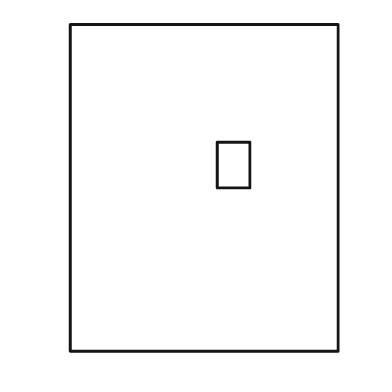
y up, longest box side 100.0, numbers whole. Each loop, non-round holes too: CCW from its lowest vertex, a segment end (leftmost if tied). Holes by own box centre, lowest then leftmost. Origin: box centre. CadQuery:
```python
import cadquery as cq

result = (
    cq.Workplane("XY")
    .moveTo(-41.0, -50.0)
    .lineTo(41.0, -50.0)
    .lineTo(41.0, 50.0)
    .lineTo(-41.0, 50.0)
    .close()
    .moveTo(4.0, 0.0)
    .lineTo(14.0, 0.0)
    .lineTo(14.0, 14.0)
    .lineTo(4.0, 14.0)
    .close()
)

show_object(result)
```